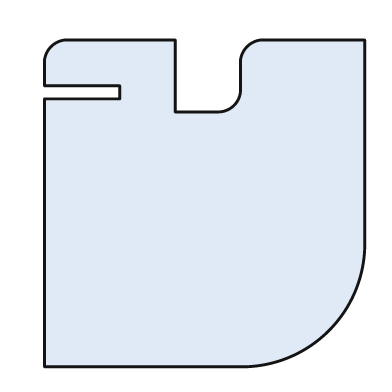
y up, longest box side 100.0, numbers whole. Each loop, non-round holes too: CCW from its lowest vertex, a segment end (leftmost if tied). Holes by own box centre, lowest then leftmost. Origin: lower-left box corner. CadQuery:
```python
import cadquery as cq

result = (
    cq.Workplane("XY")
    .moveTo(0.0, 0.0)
    .lineTo(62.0, 0.0)
    .threePointArc((87.0, 11.0), (98.0, 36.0))
    .lineTo(98.0, 100.0)
    .lineTo(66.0, 100.0)
    .threePointArc((62.0, 98.0), (60.0, 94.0))
    .lineTo(60.0, 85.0)
    .threePointArc((58.0, 80.0), (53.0, 78.0))
    .lineTo(40.0, 78.0)
    .lineTo(40.0, 100.0)
    .lineTo(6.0, 100.0)
    .threePointArc((2.0, 98.0), (0.0, 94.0))
    .lineTo(0.0, 86.0)
    .lineTo(23.0, 86.0)
    .lineTo(23.0, 82.0)
    .lineTo(0.0, 82.0)
    .close()
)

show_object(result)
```